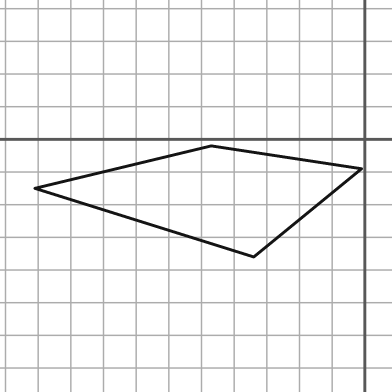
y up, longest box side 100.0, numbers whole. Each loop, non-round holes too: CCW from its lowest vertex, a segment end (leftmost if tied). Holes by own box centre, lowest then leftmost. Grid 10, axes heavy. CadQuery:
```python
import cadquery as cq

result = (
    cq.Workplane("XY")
    .moveTo(-34.0, -36.0)
    .lineTo(-1.0, -9.0)
    .lineTo(-47.0, -2.0)
    .lineTo(-101.0, -15.0)
    .close()
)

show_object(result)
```